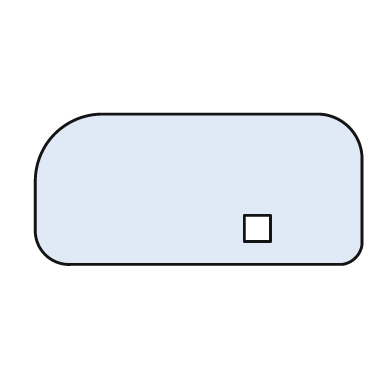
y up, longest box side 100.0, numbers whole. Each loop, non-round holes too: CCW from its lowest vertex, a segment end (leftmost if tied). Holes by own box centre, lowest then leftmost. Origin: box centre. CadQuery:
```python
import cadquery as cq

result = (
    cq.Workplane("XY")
    .moveTo(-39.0, -23.0)
    .lineTo(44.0, -23.0)
    .threePointArc((48.0, -21.0), (50.0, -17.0))
    .lineTo(50.0, 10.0)
    .threePointArc((46.0, 19.0), (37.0, 23.0))
    .lineTo(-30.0, 23.0)
    .threePointArc((-44.0, 17.0), (-50.0, 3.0))
    .lineTo(-50.0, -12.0)
    .threePointArc((-47.0, -20.0), (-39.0, -23.0))
    .close()
    .moveTo(14.0, -16.0)
    .lineTo(22.0, -16.0)
    .lineTo(22.0, -8.0)
    .lineTo(14.0, -8.0)
    .close()
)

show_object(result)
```